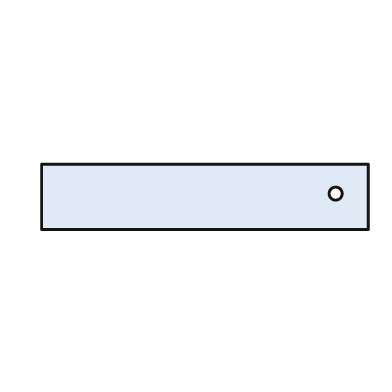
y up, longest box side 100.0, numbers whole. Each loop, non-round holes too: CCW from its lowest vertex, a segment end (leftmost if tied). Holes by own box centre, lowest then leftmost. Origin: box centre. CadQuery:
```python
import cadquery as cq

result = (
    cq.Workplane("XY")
    .moveTo(-50.0, -10.0)
    .lineTo(50.0, -10.0)
    .lineTo(50.0, 10.0)
    .lineTo(-50.0, 10.0)
    .close()
    .moveTo(40.0, 1.0)
    .circle(2.0)
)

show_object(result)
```